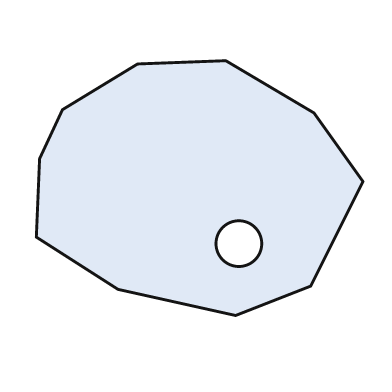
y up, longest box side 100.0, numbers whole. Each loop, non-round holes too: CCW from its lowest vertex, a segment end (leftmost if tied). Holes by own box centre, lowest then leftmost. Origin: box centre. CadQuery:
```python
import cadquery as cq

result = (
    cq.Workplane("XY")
    .moveTo(11.0, -39.0)
    .lineTo(34.0, -30.0)
    .lineTo(50.0, 2.0)
    .lineTo(35.0, 23.0)
    .lineTo(8.0, 39.0)
    .lineTo(-19.0, 38.0)
    .lineTo(-42.0, 24.0)
    .lineTo(-49.0, 9.0)
    .lineTo(-50.0, -15.0)
    .lineTo(-25.0, -31.0)
    .close()
    .moveTo(12.0, -17.0)
    .circle(7.0)
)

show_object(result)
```